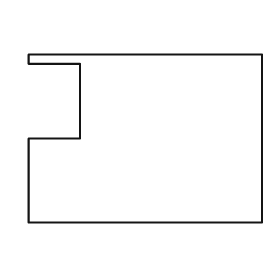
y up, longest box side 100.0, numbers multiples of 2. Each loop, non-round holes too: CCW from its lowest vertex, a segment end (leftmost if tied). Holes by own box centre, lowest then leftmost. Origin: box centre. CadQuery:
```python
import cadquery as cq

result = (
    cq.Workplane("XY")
    .moveTo(-50.0, -36.0)
    .lineTo(50.0, -36.0)
    .lineTo(50.0, 36.0)
    .lineTo(-50.0, 36.0)
    .lineTo(-50.0, 32.0)
    .lineTo(-28.0, 32.0)
    .lineTo(-28.0, 0.0)
    .lineTo(-50.0, 0.0)
    .close()
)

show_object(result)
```